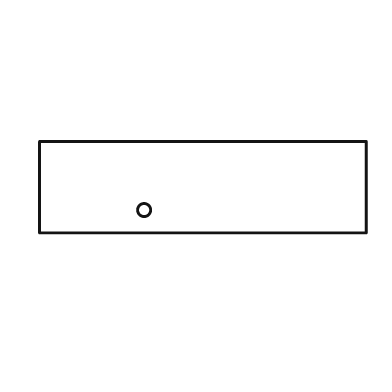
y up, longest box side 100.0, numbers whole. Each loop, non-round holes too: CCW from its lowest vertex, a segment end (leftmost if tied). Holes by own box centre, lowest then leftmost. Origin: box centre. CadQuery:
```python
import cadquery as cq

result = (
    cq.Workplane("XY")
    .moveTo(-50.0, -14.0)
    .lineTo(50.0, -14.0)
    .lineTo(50.0, 14.0)
    .lineTo(-50.0, 14.0)
    .close()
    .moveTo(-18.0, -7.0)
    .circle(2.0)
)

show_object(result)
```